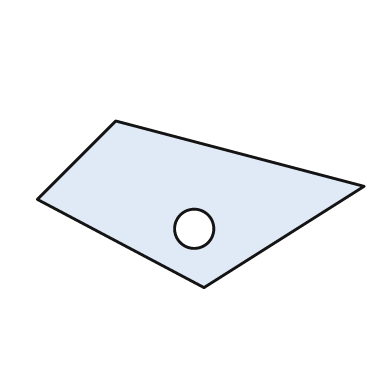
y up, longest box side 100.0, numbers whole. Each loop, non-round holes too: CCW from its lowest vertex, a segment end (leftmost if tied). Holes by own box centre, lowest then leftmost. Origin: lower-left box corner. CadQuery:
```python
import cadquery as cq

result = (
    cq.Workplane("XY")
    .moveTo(51.0, 0.0)
    .lineTo(100.0, 31.0)
    .lineTo(24.0, 51.0)
    .lineTo(0.0, 27.0)
    .close()
    .moveTo(48.0, 18.0)
    .circle(6.0)
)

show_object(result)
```